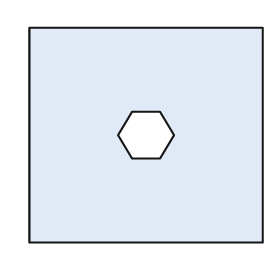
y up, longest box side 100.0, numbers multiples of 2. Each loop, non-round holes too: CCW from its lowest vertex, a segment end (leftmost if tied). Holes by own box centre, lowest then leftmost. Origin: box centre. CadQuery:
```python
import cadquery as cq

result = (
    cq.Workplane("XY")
    .moveTo(-50.0, -46.0)
    .lineTo(50.0, -46.0)
    .lineTo(50.0, 46.0)
    .lineTo(-50.0, 46.0)
    .close()
    .moveTo(-6.0, -10.0)
    .lineTo(6.0, -10.0)
    .lineTo(12.0, 0.0)
    .lineTo(6.0, 10.0)
    .lineTo(-6.0, 10.0)
    .lineTo(-12.0, 0.0)
    .close()
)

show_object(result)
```